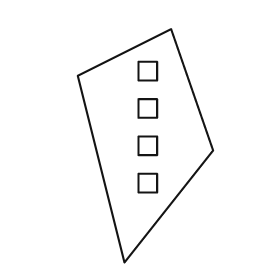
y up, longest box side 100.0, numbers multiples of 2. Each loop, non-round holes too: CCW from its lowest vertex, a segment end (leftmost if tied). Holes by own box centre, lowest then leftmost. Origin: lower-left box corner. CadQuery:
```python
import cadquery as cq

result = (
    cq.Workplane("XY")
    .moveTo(20.0, 0.0)
    .lineTo(58.0, 48.0)
    .lineTo(40.0, 100.0)
    .lineTo(0.0, 80.0)
    .close()
    .moveTo(26.0, 30.0)
    .lineTo(34.0, 30.0)
    .lineTo(34.0, 38.0)
    .lineTo(26.0, 38.0)
    .close()
    .moveTo(26.0, 46.0)
    .lineTo(34.0, 46.0)
    .lineTo(34.0, 54.0)
    .lineTo(26.0, 54.0)
    .close()
    .moveTo(26.0, 62.0)
    .lineTo(34.0, 62.0)
    .lineTo(34.0, 70.0)
    .lineTo(26.0, 70.0)
    .close()
    .moveTo(26.0, 78.0)
    .lineTo(34.0, 78.0)
    .lineTo(34.0, 86.0)
    .lineTo(26.0, 86.0)
    .close()
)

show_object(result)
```